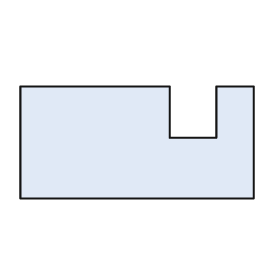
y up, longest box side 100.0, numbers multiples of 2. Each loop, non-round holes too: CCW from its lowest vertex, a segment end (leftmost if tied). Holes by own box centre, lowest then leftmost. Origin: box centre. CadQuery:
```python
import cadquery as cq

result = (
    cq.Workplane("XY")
    .moveTo(-50.0, -24.0)
    .lineTo(50.0, -24.0)
    .lineTo(50.0, 24.0)
    .lineTo(34.0, 24.0)
    .lineTo(34.0, 2.0)
    .lineTo(14.0, 2.0)
    .lineTo(14.0, 24.0)
    .lineTo(-50.0, 24.0)
    .close()
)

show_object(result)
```